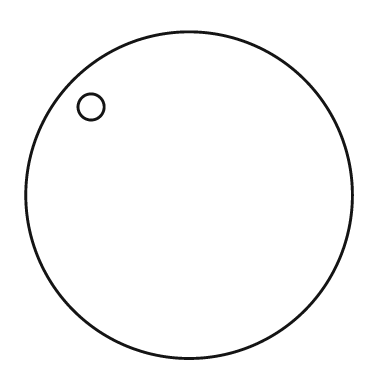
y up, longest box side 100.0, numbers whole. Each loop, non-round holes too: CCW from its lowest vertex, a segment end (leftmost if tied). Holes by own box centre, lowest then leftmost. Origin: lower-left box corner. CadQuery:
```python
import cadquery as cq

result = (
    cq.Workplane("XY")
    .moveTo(50.0, 50.0)
    .circle(50.0)
    .moveTo(20.0, 77.0)
    .circle(4.0)
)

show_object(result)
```